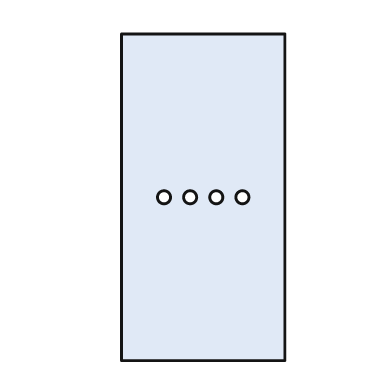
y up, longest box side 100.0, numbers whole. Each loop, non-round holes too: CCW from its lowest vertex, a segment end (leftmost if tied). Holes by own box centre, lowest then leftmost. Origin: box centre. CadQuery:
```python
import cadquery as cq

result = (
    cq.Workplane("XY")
    .moveTo(-25.0, -50.0)
    .lineTo(25.0, -50.0)
    .lineTo(25.0, 50.0)
    .lineTo(-25.0, 50.0)
    .close()
    .moveTo(-12.0, 0.0)
    .circle(2.0)
    .moveTo(-4.0, 0.0)
    .circle(2.0)
    .moveTo(4.0, 0.0)
    .circle(2.0)
    .moveTo(12.0, 0.0)
    .circle(2.0)
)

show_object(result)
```